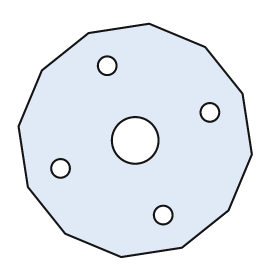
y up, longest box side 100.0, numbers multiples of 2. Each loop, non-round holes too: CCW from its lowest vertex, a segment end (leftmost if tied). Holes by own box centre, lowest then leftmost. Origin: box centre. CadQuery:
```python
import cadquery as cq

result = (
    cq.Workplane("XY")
    .moveTo(-6.0, -50.0)
    .lineTo(20.0, -46.0)
    .lineTo(40.0, -30.0)
    .lineTo(50.0, -6.0)
    .lineTo(46.0, 20.0)
    .lineTo(30.0, 40.0)
    .lineTo(6.0, 50.0)
    .lineTo(-20.0, 46.0)
    .lineTo(-40.0, 30.0)
    .lineTo(-50.0, 6.0)
    .lineTo(-46.0, -20.0)
    .lineTo(-30.0, -40.0)
    .close()
    .moveTo(12.0, -32.0)
    .circle(4.0)
    .moveTo(-32.0, -12.0)
    .circle(4.0)
    .moveTo(0.0, 0.0)
    .circle(10.0)
    .moveTo(32.0, 12.0)
    .circle(4.0)
    .moveTo(-12.0, 32.0)
    .circle(4.0)
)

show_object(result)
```